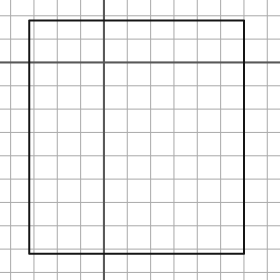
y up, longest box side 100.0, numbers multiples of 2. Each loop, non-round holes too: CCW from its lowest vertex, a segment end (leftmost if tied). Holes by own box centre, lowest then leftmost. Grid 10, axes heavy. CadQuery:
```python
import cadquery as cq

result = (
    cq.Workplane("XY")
    .moveTo(-32.0, -82.0)
    .lineTo(60.0, -82.0)
    .lineTo(60.0, 18.0)
    .lineTo(-32.0, 18.0)
    .close()
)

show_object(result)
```